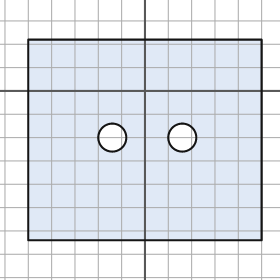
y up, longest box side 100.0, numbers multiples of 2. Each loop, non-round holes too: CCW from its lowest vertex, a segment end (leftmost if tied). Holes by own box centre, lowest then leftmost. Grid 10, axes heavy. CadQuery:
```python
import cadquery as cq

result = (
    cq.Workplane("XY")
    .moveTo(-50.0, -64.0)
    .lineTo(50.0, -64.0)
    .lineTo(50.0, 22.0)
    .lineTo(-50.0, 22.0)
    .close()
    .moveTo(-14.0, -20.0)
    .circle(6.0)
    .moveTo(16.0, -20.0)
    .circle(6.0)
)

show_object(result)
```